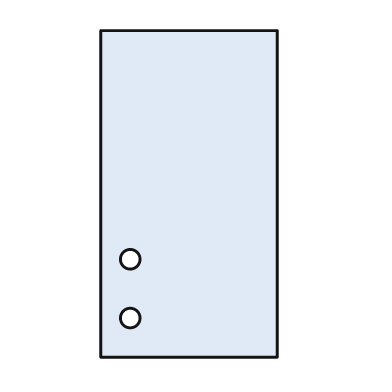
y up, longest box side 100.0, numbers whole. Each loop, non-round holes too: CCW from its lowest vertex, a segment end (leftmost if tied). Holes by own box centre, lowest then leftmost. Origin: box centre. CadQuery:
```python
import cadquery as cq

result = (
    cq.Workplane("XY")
    .moveTo(-27.0, -50.0)
    .lineTo(27.0, -50.0)
    .lineTo(27.0, 50.0)
    .lineTo(-27.0, 50.0)
    .close()
    .moveTo(-18.0, -38.0)
    .circle(3.0)
    .moveTo(-18.0, -20.0)
    .circle(3.0)
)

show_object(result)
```